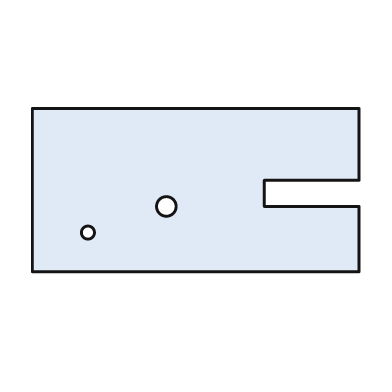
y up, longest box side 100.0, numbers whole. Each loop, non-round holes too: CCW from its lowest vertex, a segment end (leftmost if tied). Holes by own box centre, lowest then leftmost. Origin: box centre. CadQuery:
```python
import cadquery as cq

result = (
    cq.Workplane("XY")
    .moveTo(-50.0, -25.0)
    .lineTo(50.0, -25.0)
    .lineTo(50.0, -5.0)
    .lineTo(21.0, -5.0)
    .lineTo(21.0, 3.0)
    .lineTo(50.0, 3.0)
    .lineTo(50.0, 25.0)
    .lineTo(-50.0, 25.0)
    .close()
    .moveTo(-33.0, -13.0)
    .circle(2.0)
    .moveTo(-9.0, -5.0)
    .circle(3.0)
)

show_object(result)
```